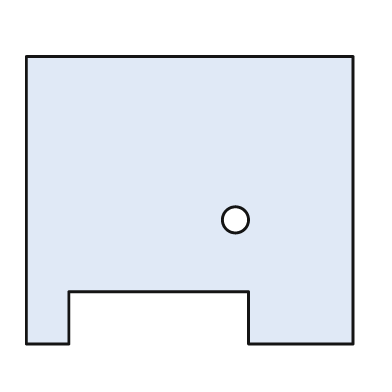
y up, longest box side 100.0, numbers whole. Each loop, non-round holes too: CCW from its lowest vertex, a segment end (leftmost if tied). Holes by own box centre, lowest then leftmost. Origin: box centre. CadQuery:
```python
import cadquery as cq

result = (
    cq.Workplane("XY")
    .moveTo(-50.0, -44.0)
    .lineTo(-37.0, -44.0)
    .lineTo(-37.0, -28.0)
    .lineTo(18.0, -28.0)
    .lineTo(18.0, -44.0)
    .lineTo(50.0, -44.0)
    .lineTo(50.0, 44.0)
    .lineTo(-50.0, 44.0)
    .close()
    .moveTo(14.0, -6.0)
    .circle(4.0)
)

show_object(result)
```